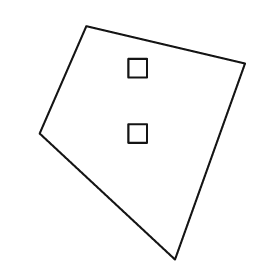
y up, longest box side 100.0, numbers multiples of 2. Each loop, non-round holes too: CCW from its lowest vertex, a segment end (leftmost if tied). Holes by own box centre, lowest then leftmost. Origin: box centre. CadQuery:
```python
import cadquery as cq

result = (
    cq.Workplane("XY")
    .moveTo(14.0, -50.0)
    .lineTo(44.0, 34.0)
    .lineTo(-24.0, 50.0)
    .lineTo(-44.0, 4.0)
    .close()
    .moveTo(-6.0, 0.0)
    .lineTo(2.0, 0.0)
    .lineTo(2.0, 8.0)
    .lineTo(-6.0, 8.0)
    .close()
    .moveTo(-6.0, 28.0)
    .lineTo(2.0, 28.0)
    .lineTo(2.0, 36.0)
    .lineTo(-6.0, 36.0)
    .close()
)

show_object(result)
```